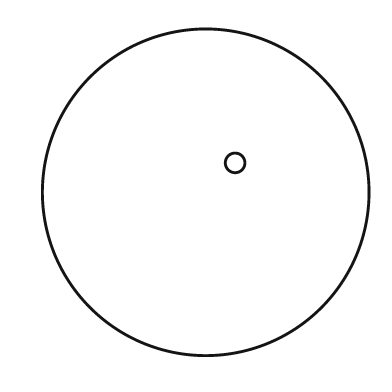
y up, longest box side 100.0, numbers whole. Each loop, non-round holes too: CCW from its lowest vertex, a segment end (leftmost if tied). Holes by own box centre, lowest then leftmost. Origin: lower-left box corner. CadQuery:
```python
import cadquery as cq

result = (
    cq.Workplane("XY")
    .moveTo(50.0, 50.0)
    .circle(50.0)
    .moveTo(59.0, 59.0)
    .circle(3.0)
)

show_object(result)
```